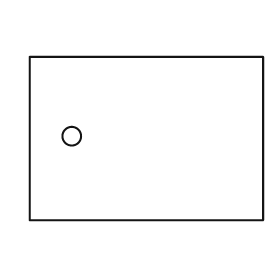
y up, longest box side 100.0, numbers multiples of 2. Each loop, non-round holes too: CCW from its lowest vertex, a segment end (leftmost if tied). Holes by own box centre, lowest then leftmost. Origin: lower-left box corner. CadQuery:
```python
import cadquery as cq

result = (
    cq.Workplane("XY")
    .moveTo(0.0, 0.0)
    .lineTo(100.0, 0.0)
    .lineTo(100.0, 70.0)
    .lineTo(0.0, 70.0)
    .close()
    .moveTo(18.0, 36.0)
    .circle(4.0)
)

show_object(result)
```